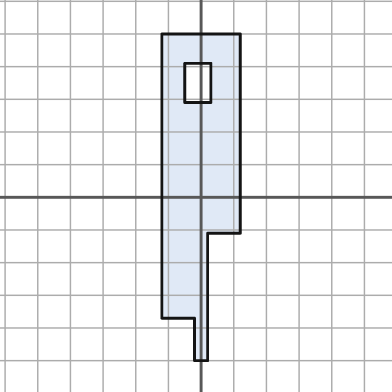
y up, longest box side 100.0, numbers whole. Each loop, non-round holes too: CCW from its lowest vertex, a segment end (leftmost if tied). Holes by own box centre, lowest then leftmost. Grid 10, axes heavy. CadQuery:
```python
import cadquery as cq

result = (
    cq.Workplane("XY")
    .moveTo(-2.0, -50.0)
    .lineTo(2.0, -50.0)
    .lineTo(2.0, -11.0)
    .lineTo(12.0, -11.0)
    .lineTo(12.0, 50.0)
    .lineTo(-12.0, 50.0)
    .lineTo(-12.0, -37.0)
    .lineTo(-2.0, -37.0)
    .close()
    .moveTo(-5.0, 29.0)
    .lineTo(3.0, 29.0)
    .lineTo(3.0, 41.0)
    .lineTo(-5.0, 41.0)
    .close()
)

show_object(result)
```